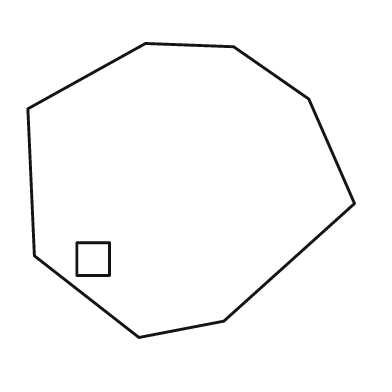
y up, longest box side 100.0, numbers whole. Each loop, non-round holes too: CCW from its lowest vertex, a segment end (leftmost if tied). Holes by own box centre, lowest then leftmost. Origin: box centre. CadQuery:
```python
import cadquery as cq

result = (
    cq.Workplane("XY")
    .moveTo(-16.0, -45.0)
    .lineTo(10.0, -40.0)
    .lineTo(50.0, -4.0)
    .lineTo(36.0, 28.0)
    .lineTo(13.0, 44.0)
    .lineTo(-14.0, 45.0)
    .lineTo(-50.0, 25.0)
    .lineTo(-48.0, -20.0)
    .close()
    .moveTo(-35.0, -26.0)
    .lineTo(-25.0, -26.0)
    .lineTo(-25.0, -16.0)
    .lineTo(-35.0, -16.0)
    .close()
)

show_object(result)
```